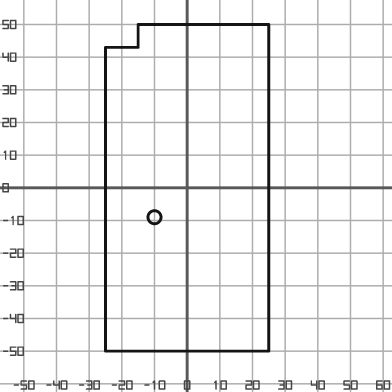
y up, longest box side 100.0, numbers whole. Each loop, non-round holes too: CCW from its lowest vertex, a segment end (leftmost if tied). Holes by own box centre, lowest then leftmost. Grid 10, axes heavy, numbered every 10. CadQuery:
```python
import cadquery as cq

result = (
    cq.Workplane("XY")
    .moveTo(-25.0, -50.0)
    .lineTo(25.0, -50.0)
    .lineTo(25.0, 50.0)
    .lineTo(-15.0, 50.0)
    .lineTo(-15.0, 43.0)
    .lineTo(-25.0, 43.0)
    .close()
    .moveTo(-10.0, -9.0)
    .circle(2.0)
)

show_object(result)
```